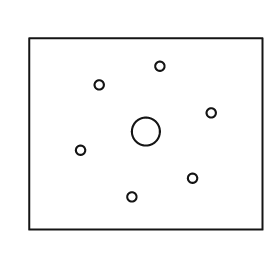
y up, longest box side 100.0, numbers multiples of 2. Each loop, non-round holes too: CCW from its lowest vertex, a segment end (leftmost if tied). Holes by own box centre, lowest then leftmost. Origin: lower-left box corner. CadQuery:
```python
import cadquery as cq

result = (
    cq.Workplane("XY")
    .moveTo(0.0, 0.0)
    .lineTo(100.0, 0.0)
    .lineTo(100.0, 82.0)
    .lineTo(0.0, 82.0)
    .close()
    .moveTo(44.0, 14.0)
    .circle(2.0)
    .moveTo(70.0, 22.0)
    .circle(2.0)
    .moveTo(22.0, 34.0)
    .circle(2.0)
    .moveTo(50.0, 42.0)
    .circle(6.0)
    .moveTo(78.0, 50.0)
    .circle(2.0)
    .moveTo(30.0, 62.0)
    .circle(2.0)
    .moveTo(56.0, 70.0)
    .circle(2.0)
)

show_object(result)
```